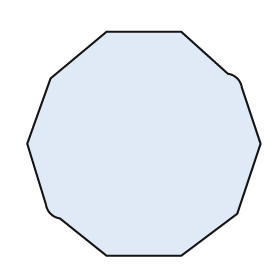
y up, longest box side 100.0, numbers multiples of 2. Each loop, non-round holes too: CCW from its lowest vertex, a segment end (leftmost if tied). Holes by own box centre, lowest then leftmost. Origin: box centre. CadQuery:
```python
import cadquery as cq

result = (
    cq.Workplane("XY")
    .moveTo(-16.0, -48.0)
    .lineTo(16.0, -48.0)
    .lineTo(40.0, -30.0)
    .lineTo(50.0, 0.0)
    .lineTo(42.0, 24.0)
    .threePointArc((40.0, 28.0), (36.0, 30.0))
    .lineTo(16.0, 48.0)
    .lineTo(-16.0, 48.0)
    .lineTo(-40.0, 28.0)
    .lineTo(-50.0, 0.0)
    .lineTo(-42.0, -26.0)
    .threePointArc((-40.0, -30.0), (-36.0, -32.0))
    .close()
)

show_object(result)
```